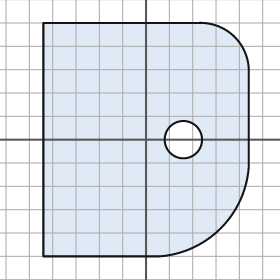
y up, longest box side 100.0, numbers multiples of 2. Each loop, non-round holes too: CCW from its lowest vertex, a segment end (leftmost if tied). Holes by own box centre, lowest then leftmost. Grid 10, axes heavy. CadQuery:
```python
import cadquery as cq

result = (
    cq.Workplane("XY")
    .moveTo(-44.0, -50.0)
    .lineTo(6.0, -50.0)
    .threePointArc((32.0, -38.0), (44.0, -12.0))
    .lineTo(44.0, 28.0)
    .threePointArc((38.0, 44.0), (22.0, 50.0))
    .lineTo(-44.0, 50.0)
    .close()
    .moveTo(16.0, 0.0)
    .circle(8.0)
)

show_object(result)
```